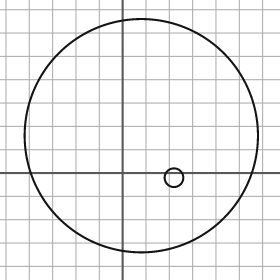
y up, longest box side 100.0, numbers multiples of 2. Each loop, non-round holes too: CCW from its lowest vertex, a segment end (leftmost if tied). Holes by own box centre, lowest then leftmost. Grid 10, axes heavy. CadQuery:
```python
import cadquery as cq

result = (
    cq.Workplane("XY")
    .moveTo(8.0, 16.0)
    .circle(50.0)
    .moveTo(22.0, -2.0)
    .circle(4.0)
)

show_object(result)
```